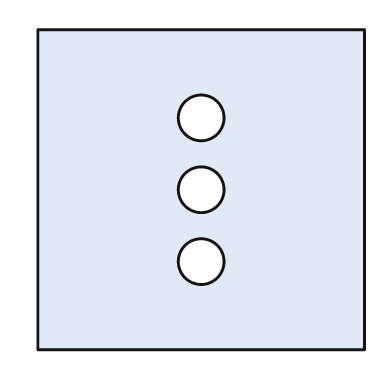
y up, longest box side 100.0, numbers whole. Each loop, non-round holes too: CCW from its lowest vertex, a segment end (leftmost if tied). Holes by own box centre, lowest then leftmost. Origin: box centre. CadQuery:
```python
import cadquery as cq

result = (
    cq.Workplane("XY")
    .moveTo(-50.0, -49.0)
    .lineTo(50.0, -49.0)
    .lineTo(50.0, 49.0)
    .lineTo(-50.0, 49.0)
    .close()
    .moveTo(0.0, -22.0)
    .circle(7.0)
    .moveTo(0.0, 0.0)
    .circle(7.0)
    .moveTo(0.0, 22.0)
    .circle(7.0)
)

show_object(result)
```